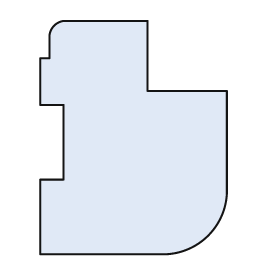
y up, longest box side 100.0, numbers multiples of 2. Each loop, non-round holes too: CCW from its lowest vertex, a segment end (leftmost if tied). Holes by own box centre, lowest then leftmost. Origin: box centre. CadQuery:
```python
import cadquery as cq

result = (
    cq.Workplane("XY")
    .moveTo(-40.0, -50.0)
    .lineTo(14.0, -50.0)
    .threePointArc((32.0, -42.0), (40.0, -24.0))
    .lineTo(40.0, 20.0)
    .lineTo(6.0, 20.0)
    .lineTo(6.0, 50.0)
    .lineTo(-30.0, 50.0)
    .threePointArc((-34.0, 48.0), (-36.0, 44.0))
    .lineTo(-36.0, 34.0)
    .lineTo(-40.0, 34.0)
    .lineTo(-40.0, 14.0)
    .lineTo(-30.0, 14.0)
    .lineTo(-30.0, -18.0)
    .lineTo(-40.0, -18.0)
    .close()
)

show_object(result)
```